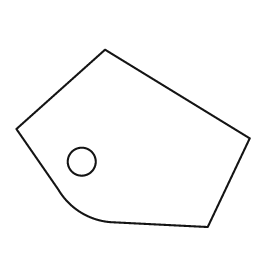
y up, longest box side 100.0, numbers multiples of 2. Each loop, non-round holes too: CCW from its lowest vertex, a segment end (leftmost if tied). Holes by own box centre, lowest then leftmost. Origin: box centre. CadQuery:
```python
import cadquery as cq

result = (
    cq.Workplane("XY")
    .moveTo(32.0, -38.0)
    .lineTo(50.0, 0.0)
    .lineTo(-12.0, 38.0)
    .lineTo(-50.0, 4.0)
    .lineTo(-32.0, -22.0)
    .threePointArc((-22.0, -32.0), (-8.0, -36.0))
    .close()
    .moveTo(-22.0, -10.0)
    .circle(6.0)
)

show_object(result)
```